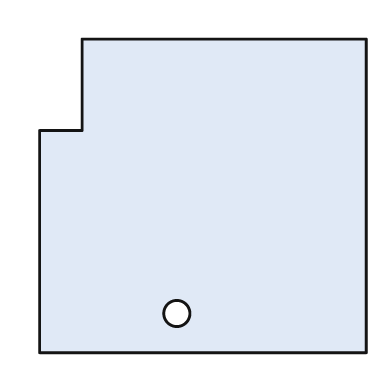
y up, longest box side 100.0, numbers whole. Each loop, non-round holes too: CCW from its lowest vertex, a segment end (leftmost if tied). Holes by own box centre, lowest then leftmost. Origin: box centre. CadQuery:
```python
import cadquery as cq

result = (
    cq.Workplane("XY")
    .moveTo(-50.0, -48.0)
    .lineTo(50.0, -48.0)
    .lineTo(50.0, 48.0)
    .lineTo(-37.0, 48.0)
    .lineTo(-37.0, 20.0)
    .lineTo(-50.0, 20.0)
    .close()
    .moveTo(-8.0, -36.0)
    .circle(4.0)
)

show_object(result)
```